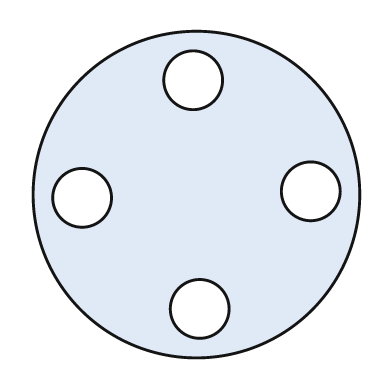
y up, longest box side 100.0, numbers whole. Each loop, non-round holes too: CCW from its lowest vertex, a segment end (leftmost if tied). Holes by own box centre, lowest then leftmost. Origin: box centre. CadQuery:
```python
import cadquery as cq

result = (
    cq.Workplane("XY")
    .moveTo(0.0, 0.0)
    .circle(50.0)
    .moveTo(1.0, -35.0)
    .circle(9.0)
    .moveTo(-35.0, -1.0)
    .circle(9.0)
    .moveTo(35.0, 1.0)
    .circle(9.0)
    .moveTo(-1.0, 35.0)
    .circle(9.0)
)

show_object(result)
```